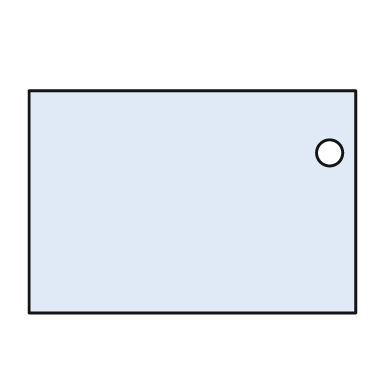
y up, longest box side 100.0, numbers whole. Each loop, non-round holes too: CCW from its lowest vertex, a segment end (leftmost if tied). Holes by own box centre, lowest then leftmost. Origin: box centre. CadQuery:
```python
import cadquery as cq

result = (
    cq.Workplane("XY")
    .moveTo(-50.0, -34.0)
    .lineTo(50.0, -34.0)
    .lineTo(50.0, 34.0)
    .lineTo(-50.0, 34.0)
    .close()
    .moveTo(42.0, 15.0)
    .circle(4.0)
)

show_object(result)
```